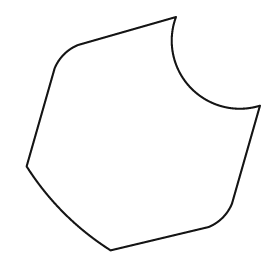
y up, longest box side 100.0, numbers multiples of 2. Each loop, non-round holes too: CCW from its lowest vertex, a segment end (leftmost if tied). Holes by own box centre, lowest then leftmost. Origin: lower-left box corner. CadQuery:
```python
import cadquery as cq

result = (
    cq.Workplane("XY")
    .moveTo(36.0, 0.0)
    .lineTo(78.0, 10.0)
    .threePointArc((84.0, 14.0), (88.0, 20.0))
    .lineTo(100.0, 62.0)
    .threePointArc((70.0, 70.0), (64.0, 100.0))
    .lineTo(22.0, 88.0)
    .threePointArc((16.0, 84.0), (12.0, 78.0))
    .lineTo(0.0, 36.0)
    .threePointArc((16.0, 16.0), (36.0, 0.0))
    .close()
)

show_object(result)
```